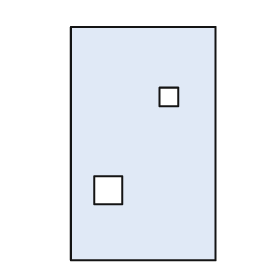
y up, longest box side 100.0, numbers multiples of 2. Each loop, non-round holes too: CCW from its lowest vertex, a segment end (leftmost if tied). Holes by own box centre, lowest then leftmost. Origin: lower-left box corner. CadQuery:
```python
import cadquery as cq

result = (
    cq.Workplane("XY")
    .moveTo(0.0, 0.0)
    .lineTo(62.0, 0.0)
    .lineTo(62.0, 100.0)
    .lineTo(0.0, 100.0)
    .close()
    .moveTo(10.0, 24.0)
    .lineTo(22.0, 24.0)
    .lineTo(22.0, 36.0)
    .lineTo(10.0, 36.0)
    .close()
    .moveTo(38.0, 66.0)
    .lineTo(46.0, 66.0)
    .lineTo(46.0, 74.0)
    .lineTo(38.0, 74.0)
    .close()
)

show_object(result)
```